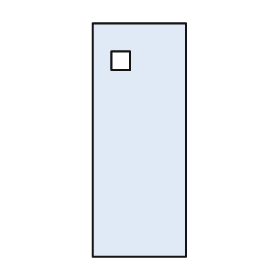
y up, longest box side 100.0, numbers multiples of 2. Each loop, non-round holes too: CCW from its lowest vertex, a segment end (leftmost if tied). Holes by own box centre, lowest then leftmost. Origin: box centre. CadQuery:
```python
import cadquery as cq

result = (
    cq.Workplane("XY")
    .moveTo(-20.0, -50.0)
    .lineTo(20.0, -50.0)
    .lineTo(20.0, 50.0)
    .lineTo(-20.0, 50.0)
    .close()
    .moveTo(-12.0, 30.0)
    .lineTo(-4.0, 30.0)
    .lineTo(-4.0, 38.0)
    .lineTo(-12.0, 38.0)
    .close()
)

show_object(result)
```